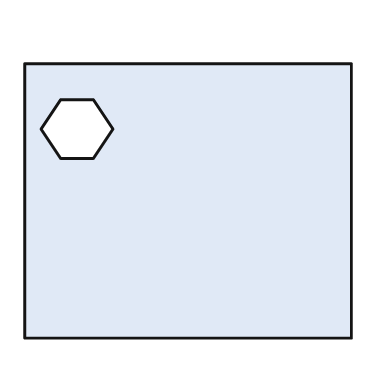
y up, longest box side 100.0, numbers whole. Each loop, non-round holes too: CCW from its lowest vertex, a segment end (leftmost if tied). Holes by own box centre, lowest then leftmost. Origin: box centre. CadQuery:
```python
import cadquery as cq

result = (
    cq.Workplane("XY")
    .moveTo(-50.0, -42.0)
    .lineTo(50.0, -42.0)
    .lineTo(50.0, 42.0)
    .lineTo(-50.0, 42.0)
    .close()
    .moveTo(-39.0, 13.0)
    .lineTo(-29.0, 13.0)
    .lineTo(-23.0, 22.0)
    .lineTo(-29.0, 31.0)
    .lineTo(-39.0, 31.0)
    .lineTo(-45.0, 22.0)
    .close()
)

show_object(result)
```